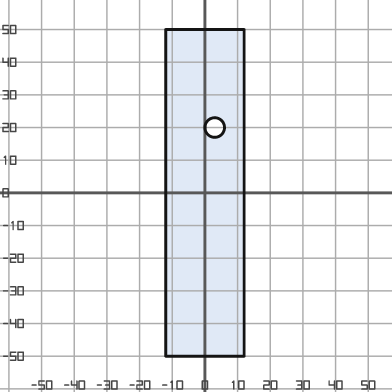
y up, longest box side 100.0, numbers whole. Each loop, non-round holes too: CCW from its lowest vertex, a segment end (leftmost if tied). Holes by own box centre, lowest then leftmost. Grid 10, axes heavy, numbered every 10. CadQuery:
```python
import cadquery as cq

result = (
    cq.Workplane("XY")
    .moveTo(-12.0, -50.0)
    .lineTo(12.0, -50.0)
    .lineTo(12.0, 50.0)
    .lineTo(-12.0, 50.0)
    .close()
    .moveTo(3.0, 20.0)
    .circle(3.0)
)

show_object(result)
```